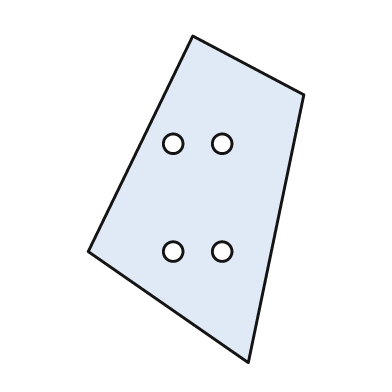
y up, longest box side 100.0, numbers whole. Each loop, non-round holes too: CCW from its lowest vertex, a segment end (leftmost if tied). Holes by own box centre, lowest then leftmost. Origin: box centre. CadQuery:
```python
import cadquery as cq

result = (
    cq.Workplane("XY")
    .moveTo(16.0, -50.0)
    .lineTo(33.0, 32.0)
    .lineTo(-1.0, 50.0)
    .lineTo(-33.0, -16.0)
    .close()
    .moveTo(-7.0, -16.0)
    .circle(3.0)
    .moveTo(8.0, -16.0)
    .circle(3.0)
    .moveTo(-7.0, 17.0)
    .circle(3.0)
    .moveTo(8.0, 17.0)
    .circle(3.0)
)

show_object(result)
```